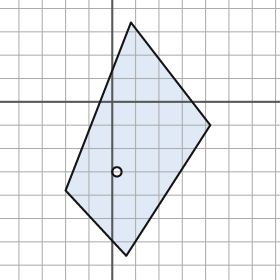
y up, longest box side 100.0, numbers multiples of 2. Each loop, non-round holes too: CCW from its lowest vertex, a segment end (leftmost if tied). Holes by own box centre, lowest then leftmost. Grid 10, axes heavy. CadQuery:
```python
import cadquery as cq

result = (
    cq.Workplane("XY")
    .moveTo(6.0, -66.0)
    .lineTo(42.0, -10.0)
    .lineTo(8.0, 34.0)
    .lineTo(-20.0, -38.0)
    .close()
    .moveTo(2.0, -30.0)
    .circle(2.0)
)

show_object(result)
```